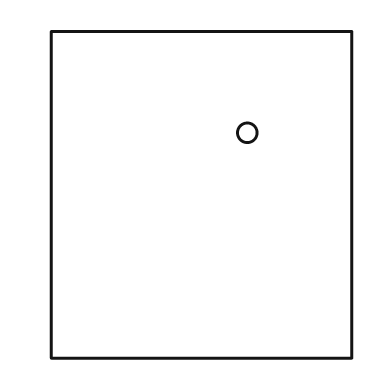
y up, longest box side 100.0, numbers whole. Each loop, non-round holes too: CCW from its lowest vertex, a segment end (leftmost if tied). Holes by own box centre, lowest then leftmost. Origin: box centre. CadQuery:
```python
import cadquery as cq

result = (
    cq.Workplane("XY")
    .moveTo(-46.0, -50.0)
    .lineTo(46.0, -50.0)
    .lineTo(46.0, 50.0)
    .lineTo(-46.0, 50.0)
    .close()
    .moveTo(14.0, 19.0)
    .circle(3.0)
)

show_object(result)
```